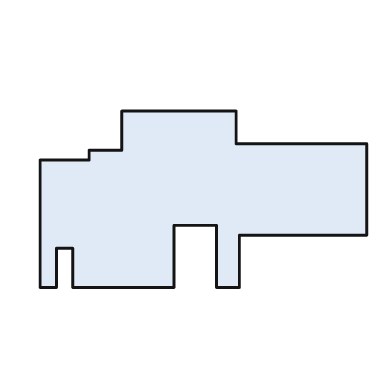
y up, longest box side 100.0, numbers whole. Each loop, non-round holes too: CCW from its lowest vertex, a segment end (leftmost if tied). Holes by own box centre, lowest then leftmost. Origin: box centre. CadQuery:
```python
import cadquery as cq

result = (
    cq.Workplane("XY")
    .moveTo(-50.0, -27.0)
    .lineTo(-45.0, -27.0)
    .lineTo(-45.0, -15.0)
    .lineTo(-40.0, -15.0)
    .lineTo(-40.0, -27.0)
    .lineTo(-9.0, -27.0)
    .lineTo(-9.0, -8.0)
    .lineTo(4.0, -8.0)
    .lineTo(4.0, -27.0)
    .lineTo(11.0, -27.0)
    .lineTo(11.0, -11.0)
    .lineTo(50.0, -11.0)
    .lineTo(50.0, 17.0)
    .lineTo(10.0, 17.0)
    .lineTo(10.0, 27.0)
    .lineTo(-25.0, 27.0)
    .lineTo(-25.0, 15.0)
    .lineTo(-35.0, 15.0)
    .lineTo(-35.0, 12.0)
    .lineTo(-50.0, 12.0)
    .close()
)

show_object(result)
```